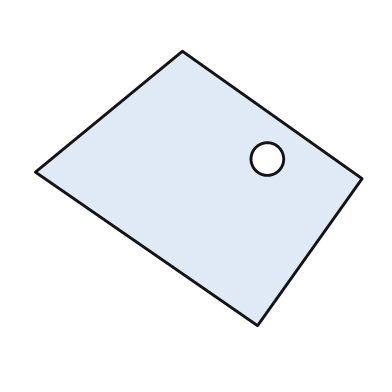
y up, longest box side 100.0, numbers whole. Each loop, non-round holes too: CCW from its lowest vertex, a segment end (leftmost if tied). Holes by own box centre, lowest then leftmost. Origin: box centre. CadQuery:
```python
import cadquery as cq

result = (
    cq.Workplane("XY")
    .moveTo(18.0, -42.0)
    .lineTo(50.0, 3.0)
    .lineTo(-5.0, 42.0)
    .lineTo(-50.0, 5.0)
    .close()
    .moveTo(21.0, 9.0)
    .circle(5.0)
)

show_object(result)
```